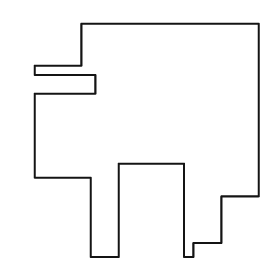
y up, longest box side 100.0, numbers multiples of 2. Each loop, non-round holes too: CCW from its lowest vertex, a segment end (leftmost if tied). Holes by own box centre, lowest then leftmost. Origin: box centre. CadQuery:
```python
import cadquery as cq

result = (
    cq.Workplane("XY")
    .moveTo(-24.0, -50.0)
    .lineTo(-12.0, -50.0)
    .lineTo(-12.0, -10.0)
    .lineTo(16.0, -10.0)
    .lineTo(16.0, -50.0)
    .lineTo(20.0, -50.0)
    .lineTo(20.0, -44.0)
    .lineTo(32.0, -44.0)
    .lineTo(32.0, -24.0)
    .lineTo(48.0, -24.0)
    .lineTo(48.0, 50.0)
    .lineTo(-28.0, 50.0)
    .lineTo(-28.0, 32.0)
    .lineTo(-48.0, 32.0)
    .lineTo(-48.0, 28.0)
    .lineTo(-22.0, 28.0)
    .lineTo(-22.0, 20.0)
    .lineTo(-48.0, 20.0)
    .lineTo(-48.0, -16.0)
    .lineTo(-24.0, -16.0)
    .close()
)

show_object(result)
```